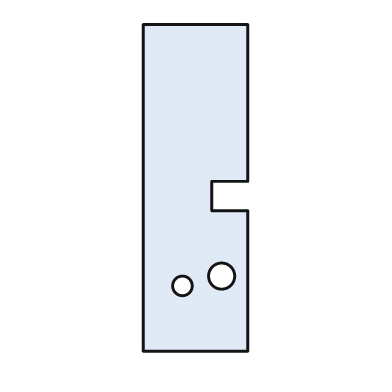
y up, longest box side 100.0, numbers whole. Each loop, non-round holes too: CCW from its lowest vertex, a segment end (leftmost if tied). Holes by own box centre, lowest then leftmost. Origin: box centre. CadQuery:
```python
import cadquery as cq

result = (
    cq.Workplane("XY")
    .moveTo(-16.0, -50.0)
    .lineTo(16.0, -50.0)
    .lineTo(16.0, -7.0)
    .lineTo(5.0, -7.0)
    .lineTo(5.0, 2.0)
    .lineTo(16.0, 2.0)
    .lineTo(16.0, 50.0)
    .lineTo(-16.0, 50.0)
    .close()
    .moveTo(-4.0, -30.0)
    .circle(3.0)
    .moveTo(8.0, -27.0)
    .circle(4.0)
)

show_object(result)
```